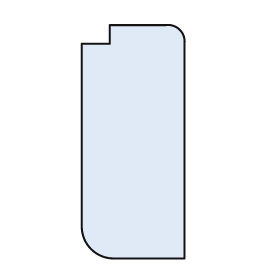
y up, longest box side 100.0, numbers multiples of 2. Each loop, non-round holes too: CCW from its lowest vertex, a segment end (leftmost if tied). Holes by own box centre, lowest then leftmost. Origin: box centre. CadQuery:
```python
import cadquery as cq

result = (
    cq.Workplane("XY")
    .moveTo(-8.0, -50.0)
    .lineTo(22.0, -50.0)
    .lineTo(22.0, 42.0)
    .threePointArc((20.0, 48.0), (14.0, 50.0))
    .lineTo(-10.0, 50.0)
    .lineTo(-10.0, 42.0)
    .lineTo(-22.0, 42.0)
    .lineTo(-22.0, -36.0)
    .threePointArc((-18.0, -46.0), (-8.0, -50.0))
    .close()
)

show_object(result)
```